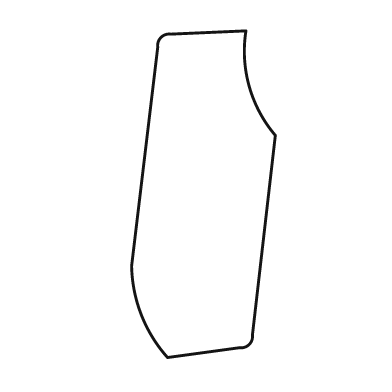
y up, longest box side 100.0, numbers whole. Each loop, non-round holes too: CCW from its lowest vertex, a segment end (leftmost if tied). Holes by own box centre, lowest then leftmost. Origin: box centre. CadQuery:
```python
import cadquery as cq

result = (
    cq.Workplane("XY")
    .moveTo(-11.0, -50.0)
    .lineTo(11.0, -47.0)
    .threePointArc((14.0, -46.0), (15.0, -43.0))
    .lineTo(22.0, 18.0)
    .threePointArc((14.0, 33.0), (13.0, 50.0))
    .lineTo(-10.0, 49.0)
    .threePointArc((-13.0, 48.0), (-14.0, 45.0))
    .lineTo(-22.0, -22.0)
    .threePointArc((-19.0, -37.0), (-11.0, -50.0))
    .close()
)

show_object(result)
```